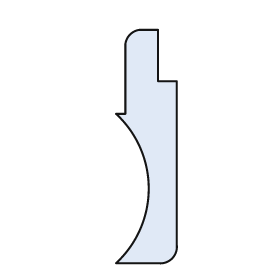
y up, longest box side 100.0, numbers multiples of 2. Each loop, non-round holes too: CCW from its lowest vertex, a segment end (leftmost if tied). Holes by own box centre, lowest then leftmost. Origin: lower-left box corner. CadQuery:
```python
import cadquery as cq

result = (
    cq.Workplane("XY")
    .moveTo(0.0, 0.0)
    .lineTo(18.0, 0.0)
    .threePointArc((24.0, 2.0), (26.0, 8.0))
    .lineTo(26.0, 78.0)
    .lineTo(18.0, 78.0)
    .lineTo(18.0, 100.0)
    .lineTo(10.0, 100.0)
    .threePointArc((6.0, 98.0), (4.0, 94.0))
    .lineTo(4.0, 64.0)
    .lineTo(0.0, 64.0)
    .threePointArc((14.0, 32.0), (0.0, 0.0))
    .close()
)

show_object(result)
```